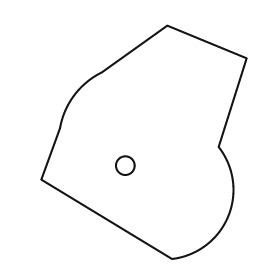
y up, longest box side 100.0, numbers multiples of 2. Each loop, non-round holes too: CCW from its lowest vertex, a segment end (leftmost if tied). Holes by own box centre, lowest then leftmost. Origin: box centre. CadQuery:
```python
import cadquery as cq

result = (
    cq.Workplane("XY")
    .moveTo(12.0, -50.0)
    .threePointArc((36.0, -32.0), (32.0, -2.0))
    .lineTo(44.0, 36.0)
    .lineTo(10.0, 50.0)
    .lineTo(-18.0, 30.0)
    .threePointArc((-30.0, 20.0), (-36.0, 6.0))
    .lineTo(-44.0, -16.0)
    .close()
    .moveTo(-8.0, -10.0)
    .circle(4.0)
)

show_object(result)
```